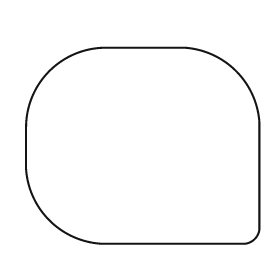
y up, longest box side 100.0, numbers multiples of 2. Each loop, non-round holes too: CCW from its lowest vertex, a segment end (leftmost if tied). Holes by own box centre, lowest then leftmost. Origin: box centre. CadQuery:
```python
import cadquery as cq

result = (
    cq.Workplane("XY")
    .moveTo(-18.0, -42.0)
    .lineTo(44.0, -42.0)
    .threePointArc((48.0, -40.0), (50.0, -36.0))
    .lineTo(50.0, 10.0)
    .threePointArc((40.0, 32.0), (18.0, 42.0))
    .lineTo(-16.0, 42.0)
    .threePointArc((-40.0, 32.0), (-50.0, 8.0))
    .lineTo(-50.0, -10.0)
    .threePointArc((-40.0, -32.0), (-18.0, -42.0))
    .close()
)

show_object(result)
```